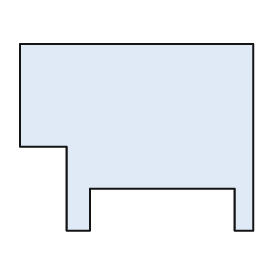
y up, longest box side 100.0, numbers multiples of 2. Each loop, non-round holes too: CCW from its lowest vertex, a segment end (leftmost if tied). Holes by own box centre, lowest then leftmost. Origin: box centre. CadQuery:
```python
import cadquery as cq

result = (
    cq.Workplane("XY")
    .moveTo(-30.0, -40.0)
    .lineTo(-20.0, -40.0)
    .lineTo(-20.0, -22.0)
    .lineTo(42.0, -22.0)
    .lineTo(42.0, -40.0)
    .lineTo(50.0, -40.0)
    .lineTo(50.0, 40.0)
    .lineTo(-50.0, 40.0)
    .lineTo(-50.0, -4.0)
    .lineTo(-30.0, -4.0)
    .close()
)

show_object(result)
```